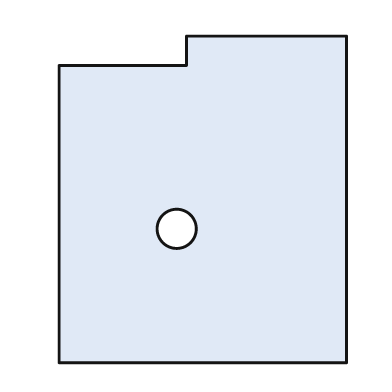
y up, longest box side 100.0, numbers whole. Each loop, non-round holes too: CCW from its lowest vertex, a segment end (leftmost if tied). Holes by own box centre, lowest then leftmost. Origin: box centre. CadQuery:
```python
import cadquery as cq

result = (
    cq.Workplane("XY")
    .moveTo(-44.0, -50.0)
    .lineTo(44.0, -50.0)
    .lineTo(44.0, 50.0)
    .lineTo(-5.0, 50.0)
    .lineTo(-5.0, 41.0)
    .lineTo(-44.0, 41.0)
    .close()
    .moveTo(-8.0, -9.0)
    .circle(6.0)
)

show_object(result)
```